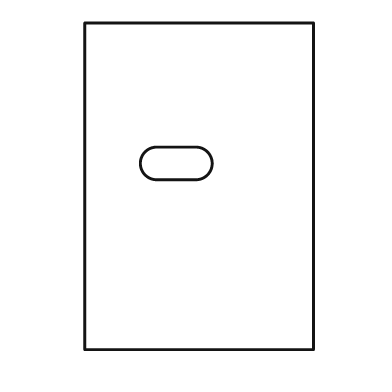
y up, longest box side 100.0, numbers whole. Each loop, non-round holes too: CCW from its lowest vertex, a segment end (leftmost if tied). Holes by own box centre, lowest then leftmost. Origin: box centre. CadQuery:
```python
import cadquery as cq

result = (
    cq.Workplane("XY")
    .moveTo(-35.0, -50.0)
    .lineTo(35.0, -50.0)
    .lineTo(35.0, 50.0)
    .lineTo(-35.0, 50.0)
    .close()
    .moveTo(-13.0, 2.0)
    .lineTo(-1.0, 2.0)
    .threePointArc((4.0, 7.0), (-1.0, 12.0))
    .lineTo(-13.0, 12.0)
    .threePointArc((-18.0, 7.0), (-13.0, 2.0))
    .close()
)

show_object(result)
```